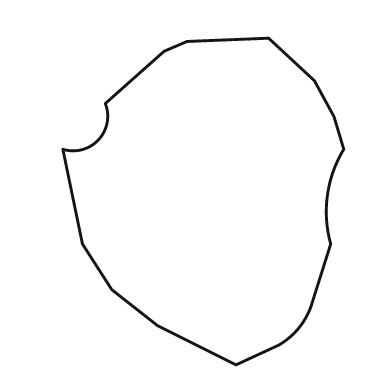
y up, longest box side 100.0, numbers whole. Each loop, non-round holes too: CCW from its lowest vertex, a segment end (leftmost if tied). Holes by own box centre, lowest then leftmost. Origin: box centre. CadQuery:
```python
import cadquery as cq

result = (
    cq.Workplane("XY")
    .moveTo(10.0, -50.0)
    .lineTo(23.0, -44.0)
    .threePointArc((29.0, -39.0), (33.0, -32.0))
    .lineTo(39.0, -13.0)
    .threePointArc((38.0, 2.0), (43.0, 16.0))
    .lineTo(40.0, 26.0)
    .lineTo(34.0, 37.0)
    .lineTo(20.0, 50.0)
    .lineTo(-5.0, 49.0)
    .lineTo(-12.0, 46.0)
    .lineTo(-30.0, 30.0)
    .threePointArc((-32.0, 19.0), (-43.0, 16.0))
    .lineTo(-37.0, -13.0)
    .lineTo(-28.0, -27.0)
    .lineTo(-14.0, -38.0)
    .close()
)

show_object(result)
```